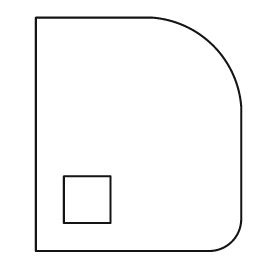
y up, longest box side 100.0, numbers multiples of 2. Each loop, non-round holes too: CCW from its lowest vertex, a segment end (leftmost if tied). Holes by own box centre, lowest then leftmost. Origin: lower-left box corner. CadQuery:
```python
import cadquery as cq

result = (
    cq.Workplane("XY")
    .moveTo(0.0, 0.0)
    .lineTo(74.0, 0.0)
    .threePointArc((84.0, 4.0), (88.0, 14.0))
    .lineTo(88.0, 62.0)
    .threePointArc((76.0, 88.0), (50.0, 100.0))
    .lineTo(0.0, 100.0)
    .close()
    .moveTo(12.0, 12.0)
    .lineTo(32.0, 12.0)
    .lineTo(32.0, 32.0)
    .lineTo(12.0, 32.0)
    .close()
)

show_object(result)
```